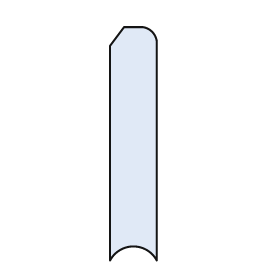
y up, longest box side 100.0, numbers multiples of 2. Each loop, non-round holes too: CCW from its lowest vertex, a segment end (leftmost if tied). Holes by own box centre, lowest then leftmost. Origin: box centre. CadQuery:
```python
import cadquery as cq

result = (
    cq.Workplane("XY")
    .moveTo(-10.0, -50.0)
    .threePointArc((0.0, -44.0), (10.0, -50.0))
    .lineTo(10.0, 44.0)
    .threePointArc((8.0, 48.0), (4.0, 50.0))
    .lineTo(-4.0, 50.0)
    .lineTo(-10.0, 42.0)
    .close()
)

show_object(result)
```